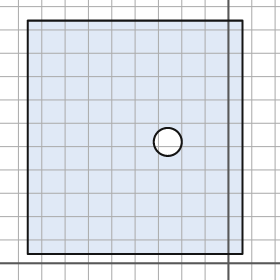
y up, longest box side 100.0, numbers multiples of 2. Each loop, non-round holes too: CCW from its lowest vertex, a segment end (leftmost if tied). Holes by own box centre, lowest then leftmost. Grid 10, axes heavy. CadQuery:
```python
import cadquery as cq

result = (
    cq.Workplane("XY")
    .moveTo(-86.0, 4.0)
    .lineTo(6.0, 4.0)
    .lineTo(6.0, 104.0)
    .lineTo(-86.0, 104.0)
    .close()
    .moveTo(-26.0, 52.0)
    .circle(6.0)
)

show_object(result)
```